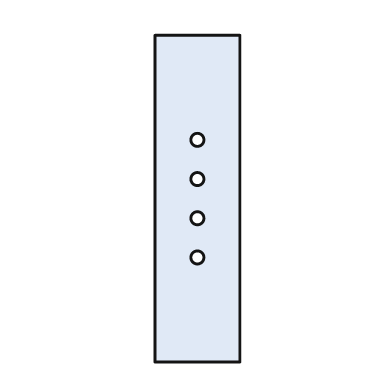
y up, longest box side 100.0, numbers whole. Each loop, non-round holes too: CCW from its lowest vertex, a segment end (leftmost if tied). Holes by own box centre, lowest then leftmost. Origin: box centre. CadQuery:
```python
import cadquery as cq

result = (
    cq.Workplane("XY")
    .moveTo(-13.0, -50.0)
    .lineTo(13.0, -50.0)
    .lineTo(13.0, 50.0)
    .lineTo(-13.0, 50.0)
    .close()
    .moveTo(0.0, -18.0)
    .circle(2.0)
    .moveTo(0.0, -6.0)
    .circle(2.0)
    .moveTo(0.0, 6.0)
    .circle(2.0)
    .moveTo(0.0, 18.0)
    .circle(2.0)
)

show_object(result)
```